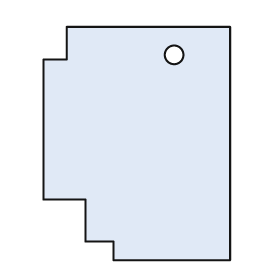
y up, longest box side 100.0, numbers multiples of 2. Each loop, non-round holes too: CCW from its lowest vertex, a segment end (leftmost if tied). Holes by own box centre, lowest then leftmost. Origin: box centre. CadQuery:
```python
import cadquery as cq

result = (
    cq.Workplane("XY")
    .moveTo(-10.0, -50.0)
    .lineTo(40.0, -50.0)
    .lineTo(40.0, 50.0)
    .lineTo(-30.0, 50.0)
    .lineTo(-30.0, 36.0)
    .lineTo(-40.0, 36.0)
    .lineTo(-40.0, -24.0)
    .lineTo(-22.0, -24.0)
    .lineTo(-22.0, -42.0)
    .lineTo(-10.0, -42.0)
    .close()
    .moveTo(16.0, 38.0)
    .circle(4.0)
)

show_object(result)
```